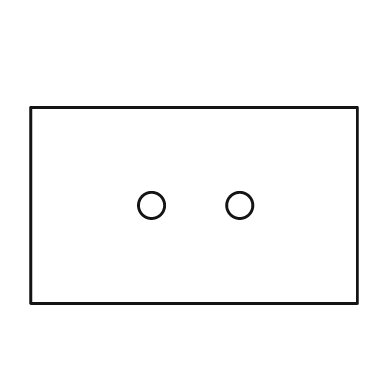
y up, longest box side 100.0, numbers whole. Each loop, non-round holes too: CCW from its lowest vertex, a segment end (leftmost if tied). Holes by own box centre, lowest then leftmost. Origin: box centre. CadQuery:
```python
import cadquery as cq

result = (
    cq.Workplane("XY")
    .moveTo(-50.0, -30.0)
    .lineTo(50.0, -30.0)
    .lineTo(50.0, 30.0)
    .lineTo(-50.0, 30.0)
    .close()
    .moveTo(-13.0, 0.0)
    .circle(4.0)
    .moveTo(14.0, 0.0)
    .circle(4.0)
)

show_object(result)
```